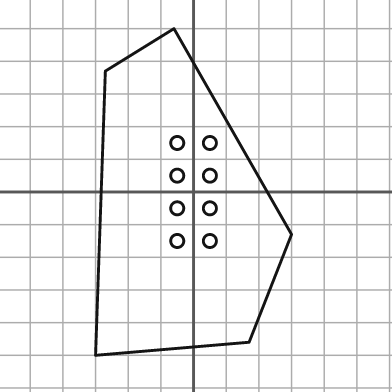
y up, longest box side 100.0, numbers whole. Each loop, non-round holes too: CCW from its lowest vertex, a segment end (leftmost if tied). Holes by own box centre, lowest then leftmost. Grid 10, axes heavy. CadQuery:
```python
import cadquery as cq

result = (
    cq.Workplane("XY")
    .moveTo(-30.0, -50.0)
    .lineTo(17.0, -46.0)
    .lineTo(30.0, -13.0)
    .lineTo(-6.0, 50.0)
    .lineTo(-27.0, 37.0)
    .close()
    .moveTo(-5.0, -15.0)
    .circle(2.0)
    .moveTo(5.0, -15.0)
    .circle(2.0)
    .moveTo(-5.0, -5.0)
    .circle(2.0)
    .moveTo(5.0, -5.0)
    .circle(2.0)
    .moveTo(-5.0, 5.0)
    .circle(2.0)
    .moveTo(5.0, 5.0)
    .circle(2.0)
    .moveTo(-5.0, 15.0)
    .circle(2.0)
    .moveTo(5.0, 15.0)
    .circle(2.0)
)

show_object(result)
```